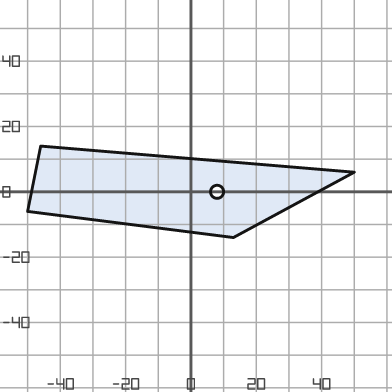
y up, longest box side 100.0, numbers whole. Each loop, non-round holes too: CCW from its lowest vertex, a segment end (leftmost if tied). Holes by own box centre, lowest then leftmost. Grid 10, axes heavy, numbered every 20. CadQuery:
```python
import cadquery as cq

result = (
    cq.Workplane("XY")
    .moveTo(13.0, -14.0)
    .lineTo(50.0, 6.0)
    .lineTo(-46.0, 14.0)
    .lineTo(-50.0, -6.0)
    .close()
    .moveTo(8.0, 0.0)
    .circle(2.0)
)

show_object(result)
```